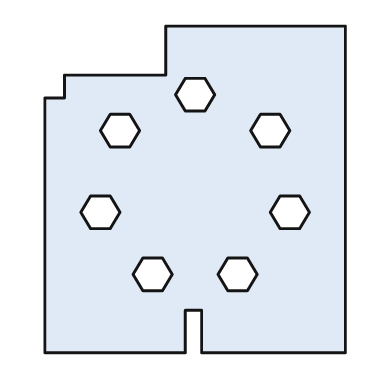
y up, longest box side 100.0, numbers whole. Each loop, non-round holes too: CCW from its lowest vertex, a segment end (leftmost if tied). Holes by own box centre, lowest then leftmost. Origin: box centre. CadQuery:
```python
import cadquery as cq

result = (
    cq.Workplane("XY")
    .moveTo(-46.0, -50.0)
    .lineTo(-3.0, -50.0)
    .lineTo(-3.0, -37.0)
    .lineTo(2.0, -37.0)
    .lineTo(2.0, -50.0)
    .lineTo(46.0, -50.0)
    .lineTo(46.0, 50.0)
    .lineTo(-9.0, 50.0)
    .lineTo(-9.0, 35.0)
    .lineTo(-40.0, 35.0)
    .lineTo(-40.0, 28.0)
    .lineTo(-46.0, 28.0)
    .close()
    .moveTo(-16.0, -31.0)
    .lineTo(-10.0, -31.0)
    .lineTo(-7.0, -26.0)
    .lineTo(-10.0, -21.0)
    .lineTo(-16.0, -21.0)
    .lineTo(-19.0, -26.0)
    .close()
    .moveTo(10.0, -31.0)
    .lineTo(16.0, -31.0)
    .lineTo(19.0, -26.0)
    .lineTo(16.0, -21.0)
    .lineTo(10.0, -21.0)
    .lineTo(7.0, -26.0)
    .close()
    .moveTo(-32.0, -12.0)
    .lineTo(-26.0, -12.0)
    .lineTo(-23.0, -7.0)
    .lineTo(-26.0, -2.0)
    .lineTo(-32.0, -2.0)
    .lineTo(-35.0, -7.0)
    .close()
    .moveTo(26.0, -12.0)
    .lineTo(32.0, -12.0)
    .lineTo(35.0, -7.0)
    .lineTo(32.0, -2.0)
    .lineTo(26.0, -2.0)
    .lineTo(23.0, -7.0)
    .close()
    .moveTo(-26.0, 13.0)
    .lineTo(-20.0, 13.0)
    .lineTo(-17.0, 18.0)
    .lineTo(-20.0, 23.0)
    .lineTo(-26.0, 23.0)
    .lineTo(-29.0, 18.0)
    .close()
    .moveTo(20.0, 13.0)
    .lineTo(26.0, 13.0)
    .lineTo(29.0, 18.0)
    .lineTo(26.0, 23.0)
    .lineTo(20.0, 23.0)
    .lineTo(17.0, 18.0)
    .close()
    .moveTo(-3.0, 24.0)
    .lineTo(3.0, 24.0)
    .lineTo(6.0, 29.0)
    .lineTo(3.0, 34.0)
    .lineTo(-3.0, 34.0)
    .lineTo(-6.0, 29.0)
    .close()
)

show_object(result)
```